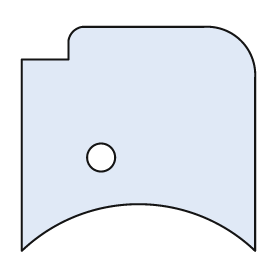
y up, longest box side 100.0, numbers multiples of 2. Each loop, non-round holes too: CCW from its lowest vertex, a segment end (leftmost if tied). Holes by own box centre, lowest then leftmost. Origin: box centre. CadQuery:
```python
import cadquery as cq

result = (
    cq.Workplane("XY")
    .moveTo(-50.0, -48.0)
    .threePointArc((0.0, -28.0), (50.0, -48.0))
    .lineTo(50.0, 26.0)
    .threePointArc((44.0, 42.0), (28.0, 48.0))
    .lineTo(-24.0, 48.0)
    .threePointArc((-28.0, 46.0), (-30.0, 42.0))
    .lineTo(-30.0, 34.0)
    .lineTo(-50.0, 34.0)
    .close()
    .moveTo(-16.0, -8.0)
    .circle(6.0)
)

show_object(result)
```